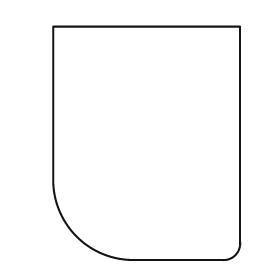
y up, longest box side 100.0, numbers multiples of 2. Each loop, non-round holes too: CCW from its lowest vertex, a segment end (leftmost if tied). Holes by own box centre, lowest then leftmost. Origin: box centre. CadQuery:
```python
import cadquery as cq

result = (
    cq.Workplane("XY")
    .moveTo(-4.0, -50.0)
    .lineTo(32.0, -50.0)
    .threePointArc((38.0, -48.0), (40.0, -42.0))
    .lineTo(40.0, 50.0)
    .lineTo(-40.0, 50.0)
    .lineTo(-40.0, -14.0)
    .threePointArc((-30.0, -40.0), (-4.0, -50.0))
    .close()
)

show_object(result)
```